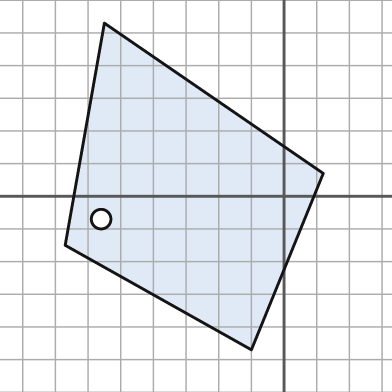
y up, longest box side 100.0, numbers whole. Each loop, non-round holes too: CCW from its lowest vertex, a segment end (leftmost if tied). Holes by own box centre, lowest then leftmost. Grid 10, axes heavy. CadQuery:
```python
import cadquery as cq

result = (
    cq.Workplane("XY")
    .moveTo(-10.0, -47.0)
    .lineTo(12.0, 7.0)
    .lineTo(-55.0, 53.0)
    .lineTo(-67.0, -15.0)
    .close()
    .moveTo(-56.0, -7.0)
    .circle(3.0)
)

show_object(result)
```